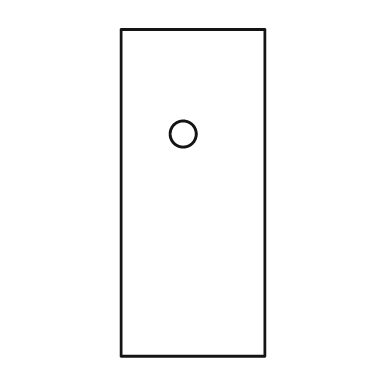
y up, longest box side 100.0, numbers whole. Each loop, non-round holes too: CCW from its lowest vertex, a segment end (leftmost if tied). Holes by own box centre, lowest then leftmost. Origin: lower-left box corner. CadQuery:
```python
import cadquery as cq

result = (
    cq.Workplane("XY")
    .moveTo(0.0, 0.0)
    .lineTo(44.0, 0.0)
    .lineTo(44.0, 100.0)
    .lineTo(0.0, 100.0)
    .close()
    .moveTo(19.0, 68.0)
    .circle(4.0)
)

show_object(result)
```